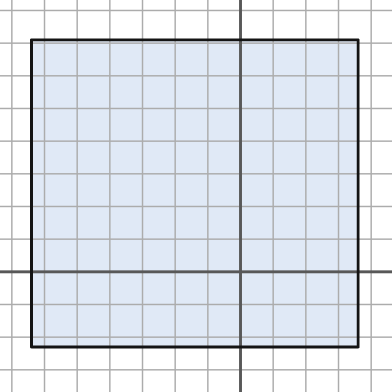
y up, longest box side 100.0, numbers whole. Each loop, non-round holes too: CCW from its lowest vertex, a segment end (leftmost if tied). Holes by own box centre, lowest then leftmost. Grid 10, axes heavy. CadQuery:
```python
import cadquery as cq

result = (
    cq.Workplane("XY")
    .moveTo(-64.0, -23.0)
    .lineTo(36.0, -23.0)
    .lineTo(36.0, 71.0)
    .lineTo(-64.0, 71.0)
    .close()
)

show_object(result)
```